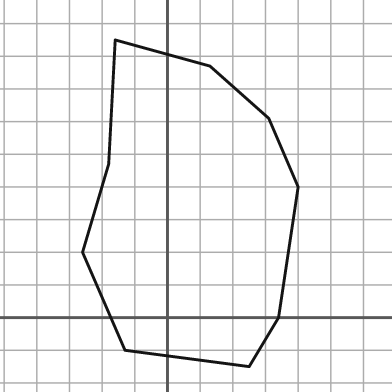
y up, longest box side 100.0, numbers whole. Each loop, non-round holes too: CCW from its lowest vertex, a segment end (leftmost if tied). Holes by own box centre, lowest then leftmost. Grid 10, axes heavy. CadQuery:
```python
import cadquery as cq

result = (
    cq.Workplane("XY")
    .moveTo(25.0, -15.0)
    .lineTo(34.0, 0.0)
    .lineTo(40.0, 40.0)
    .lineTo(31.0, 61.0)
    .lineTo(13.0, 77.0)
    .lineTo(-16.0, 85.0)
    .lineTo(-18.0, 47.0)
    .lineTo(-26.0, 20.0)
    .lineTo(-13.0, -10.0)
    .close()
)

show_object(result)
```